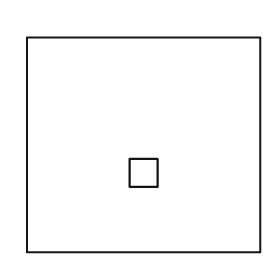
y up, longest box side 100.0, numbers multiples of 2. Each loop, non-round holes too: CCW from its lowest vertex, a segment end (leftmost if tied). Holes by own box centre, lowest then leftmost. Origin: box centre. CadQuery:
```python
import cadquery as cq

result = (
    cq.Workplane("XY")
    .moveTo(-50.0, -46.0)
    .lineTo(50.0, -46.0)
    .lineTo(50.0, 46.0)
    .lineTo(-50.0, 46.0)
    .close()
    .moveTo(-6.0, -18.0)
    .lineTo(6.0, -18.0)
    .lineTo(6.0, -6.0)
    .lineTo(-6.0, -6.0)
    .close()
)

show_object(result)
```